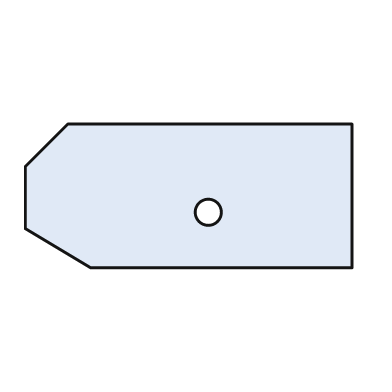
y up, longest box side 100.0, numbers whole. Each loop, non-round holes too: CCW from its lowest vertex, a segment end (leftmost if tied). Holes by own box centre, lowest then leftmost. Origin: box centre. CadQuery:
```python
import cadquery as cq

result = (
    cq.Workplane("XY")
    .moveTo(-30.0, -22.0)
    .lineTo(50.0, -22.0)
    .lineTo(50.0, 22.0)
    .lineTo(-37.0, 22.0)
    .lineTo(-50.0, 9.0)
    .lineTo(-50.0, -10.0)
    .close()
    .moveTo(6.0, -5.0)
    .circle(4.0)
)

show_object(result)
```